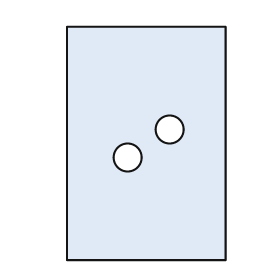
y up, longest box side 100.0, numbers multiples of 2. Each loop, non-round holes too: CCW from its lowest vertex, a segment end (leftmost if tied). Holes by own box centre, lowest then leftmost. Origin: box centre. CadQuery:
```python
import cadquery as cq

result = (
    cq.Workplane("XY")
    .moveTo(-34.0, -50.0)
    .lineTo(34.0, -50.0)
    .lineTo(34.0, 50.0)
    .lineTo(-34.0, 50.0)
    .close()
    .moveTo(-8.0, -6.0)
    .circle(6.0)
    .moveTo(10.0, 6.0)
    .circle(6.0)
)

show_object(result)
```